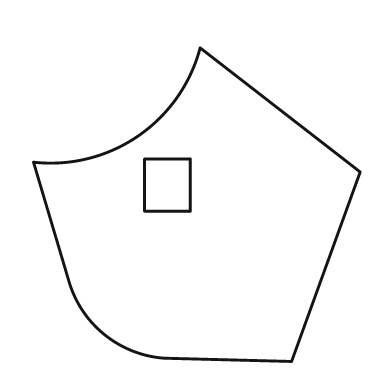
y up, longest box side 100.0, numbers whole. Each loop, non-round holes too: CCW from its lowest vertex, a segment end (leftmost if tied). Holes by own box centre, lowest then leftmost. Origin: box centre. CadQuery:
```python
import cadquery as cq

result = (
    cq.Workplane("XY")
    .moveTo(29.0, -48.0)
    .lineTo(50.0, 10.0)
    .lineTo(1.0, 48.0)
    .threePointArc((-18.0, 21.0), (-50.0, 13.0))
    .lineTo(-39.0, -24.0)
    .threePointArc((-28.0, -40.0), (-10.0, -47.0))
    .close()
    .moveTo(-16.0, -2.0)
    .lineTo(-2.0, -2.0)
    .lineTo(-2.0, 14.0)
    .lineTo(-16.0, 14.0)
    .close()
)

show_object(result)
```